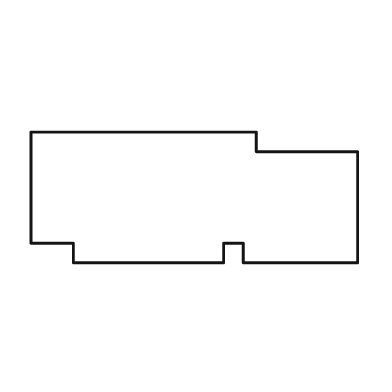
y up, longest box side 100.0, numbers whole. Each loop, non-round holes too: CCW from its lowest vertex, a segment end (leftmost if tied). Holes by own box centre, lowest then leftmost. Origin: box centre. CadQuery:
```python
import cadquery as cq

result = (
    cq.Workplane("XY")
    .moveTo(-37.0, -20.0)
    .lineTo(9.0, -20.0)
    .lineTo(9.0, -14.0)
    .lineTo(15.0, -14.0)
    .lineTo(15.0, -20.0)
    .lineTo(50.0, -20.0)
    .lineTo(50.0, 14.0)
    .lineTo(19.0, 14.0)
    .lineTo(19.0, 20.0)
    .lineTo(-50.0, 20.0)
    .lineTo(-50.0, -14.0)
    .lineTo(-37.0, -14.0)
    .close()
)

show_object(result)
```